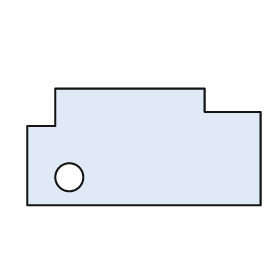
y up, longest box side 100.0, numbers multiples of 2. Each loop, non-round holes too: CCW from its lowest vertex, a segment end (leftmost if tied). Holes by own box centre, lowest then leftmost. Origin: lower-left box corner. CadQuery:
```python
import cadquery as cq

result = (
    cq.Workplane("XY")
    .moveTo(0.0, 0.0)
    .lineTo(100.0, 0.0)
    .lineTo(100.0, 40.0)
    .lineTo(76.0, 40.0)
    .lineTo(76.0, 50.0)
    .lineTo(12.0, 50.0)
    .lineTo(12.0, 34.0)
    .lineTo(0.0, 34.0)
    .close()
    .moveTo(18.0, 12.0)
    .circle(6.0)
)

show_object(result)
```